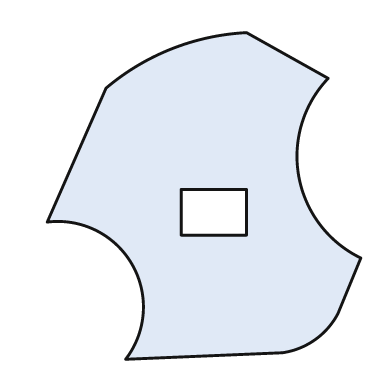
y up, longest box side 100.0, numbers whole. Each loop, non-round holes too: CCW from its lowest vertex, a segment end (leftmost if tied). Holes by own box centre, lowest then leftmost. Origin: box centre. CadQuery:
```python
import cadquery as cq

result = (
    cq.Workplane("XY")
    .moveTo(-24.0, -50.0)
    .lineTo(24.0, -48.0)
    .threePointArc((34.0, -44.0), (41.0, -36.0))
    .lineTo(48.0, -19.0)
    .threePointArc((29.0, 6.0), (38.0, 36.0))
    .lineTo(13.0, 50.0)
    .threePointArc((-10.0, 45.0), (-30.0, 33.0))
    .lineTo(-48.0, -8.0)
    .threePointArc((-22.0, -21.0), (-24.0, -50.0))
    .close()
    .moveTo(-7.0, -12.0)
    .lineTo(13.0, -12.0)
    .lineTo(13.0, 2.0)
    .lineTo(-7.0, 2.0)
    .close()
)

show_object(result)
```